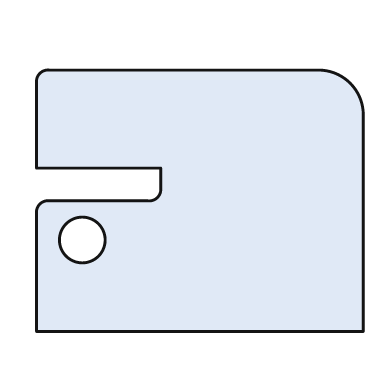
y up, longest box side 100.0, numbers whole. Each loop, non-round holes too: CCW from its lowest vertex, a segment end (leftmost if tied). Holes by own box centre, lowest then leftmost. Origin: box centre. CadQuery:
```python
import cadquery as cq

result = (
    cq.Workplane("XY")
    .moveTo(-50.0, -40.0)
    .lineTo(50.0, -40.0)
    .lineTo(50.0, 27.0)
    .threePointArc((46.0, 36.0), (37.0, 40.0))
    .lineTo(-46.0, 40.0)
    .threePointArc((-49.0, 39.0), (-50.0, 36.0))
    .lineTo(-50.0, 10.0)
    .lineTo(-12.0, 10.0)
    .lineTo(-12.0, 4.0)
    .threePointArc((-13.0, 1.0), (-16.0, 0.0))
    .lineTo(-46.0, 0.0)
    .threePointArc((-49.0, -1.0), (-50.0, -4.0))
    .close()
    .moveTo(-36.0, -12.0)
    .circle(7.0)
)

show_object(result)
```